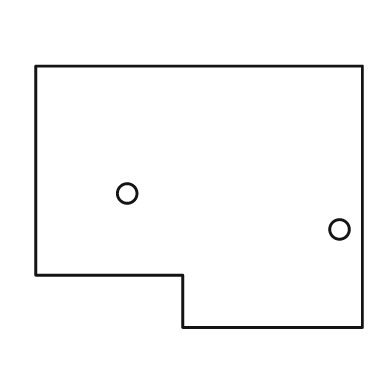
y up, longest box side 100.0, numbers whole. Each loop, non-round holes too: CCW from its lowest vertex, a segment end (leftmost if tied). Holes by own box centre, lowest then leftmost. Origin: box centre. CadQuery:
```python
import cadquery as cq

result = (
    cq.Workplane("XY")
    .moveTo(-5.0, -40.0)
    .lineTo(50.0, -40.0)
    .lineTo(50.0, 40.0)
    .lineTo(-50.0, 40.0)
    .lineTo(-50.0, -24.0)
    .lineTo(-5.0, -24.0)
    .close()
    .moveTo(43.0, -10.0)
    .circle(3.0)
    .moveTo(-22.0, 1.0)
    .circle(3.0)
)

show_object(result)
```